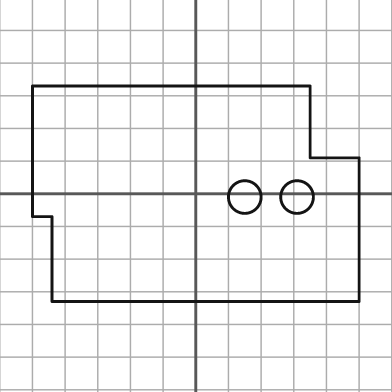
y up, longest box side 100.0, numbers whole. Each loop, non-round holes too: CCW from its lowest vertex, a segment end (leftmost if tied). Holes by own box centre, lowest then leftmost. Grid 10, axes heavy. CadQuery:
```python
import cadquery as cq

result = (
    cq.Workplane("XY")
    .moveTo(-44.0, -33.0)
    .lineTo(50.0, -33.0)
    .lineTo(50.0, 11.0)
    .lineTo(35.0, 11.0)
    .lineTo(35.0, 33.0)
    .lineTo(-50.0, 33.0)
    .lineTo(-50.0, -7.0)
    .lineTo(-44.0, -7.0)
    .close()
    .moveTo(15.0, -1.0)
    .circle(5.0)
    .moveTo(31.0, -1.0)
    .circle(5.0)
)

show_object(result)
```